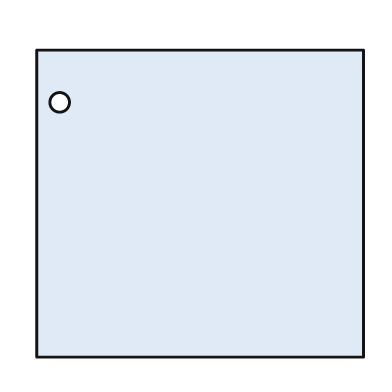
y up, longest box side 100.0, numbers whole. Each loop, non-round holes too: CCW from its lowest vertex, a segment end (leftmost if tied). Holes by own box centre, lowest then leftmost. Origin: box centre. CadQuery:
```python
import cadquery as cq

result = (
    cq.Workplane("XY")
    .moveTo(-50.0, -47.0)
    .lineTo(50.0, -47.0)
    .lineTo(50.0, 47.0)
    .lineTo(-50.0, 47.0)
    .close()
    .moveTo(-43.0, 31.0)
    .circle(3.0)
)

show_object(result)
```